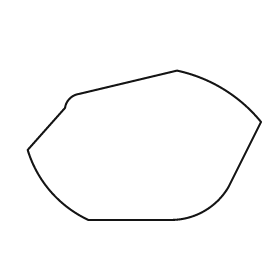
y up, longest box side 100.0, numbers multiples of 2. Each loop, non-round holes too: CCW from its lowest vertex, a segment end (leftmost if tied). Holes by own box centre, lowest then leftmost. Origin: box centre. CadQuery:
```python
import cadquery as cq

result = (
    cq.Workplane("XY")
    .moveTo(-24.0, -32.0)
    .lineTo(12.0, -32.0)
    .threePointArc((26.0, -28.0), (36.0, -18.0))
    .lineTo(50.0, 10.0)
    .threePointArc((34.0, 24.0), (14.0, 32.0))
    .lineTo(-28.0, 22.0)
    .threePointArc((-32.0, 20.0), (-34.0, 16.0))
    .lineTo(-50.0, -2.0)
    .threePointArc((-40.0, -20.0), (-24.0, -32.0))
    .close()
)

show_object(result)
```